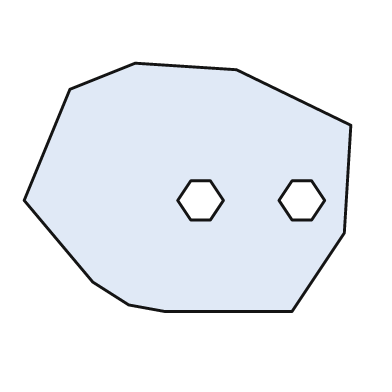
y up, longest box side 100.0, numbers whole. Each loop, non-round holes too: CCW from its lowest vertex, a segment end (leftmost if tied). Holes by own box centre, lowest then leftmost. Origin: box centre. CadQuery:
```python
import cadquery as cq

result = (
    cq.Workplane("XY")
    .moveTo(-7.0, -38.0)
    .lineTo(32.0, -38.0)
    .lineTo(48.0, -14.0)
    .lineTo(50.0, 19.0)
    .lineTo(15.0, 36.0)
    .lineTo(-16.0, 38.0)
    .lineTo(-36.0, 30.0)
    .lineTo(-50.0, -4.0)
    .lineTo(-29.0, -29.0)
    .lineTo(-18.0, -36.0)
    .close()
    .moveTo(1.0, -10.0)
    .lineTo(7.0, -10.0)
    .lineTo(11.0, -4.0)
    .lineTo(7.0, 2.0)
    .lineTo(1.0, 2.0)
    .lineTo(-3.0, -4.0)
    .close()
    .moveTo(32.0, -10.0)
    .lineTo(38.0, -10.0)
    .lineTo(42.0, -4.0)
    .lineTo(38.0, 2.0)
    .lineTo(32.0, 2.0)
    .lineTo(28.0, -4.0)
    .close()
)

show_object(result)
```